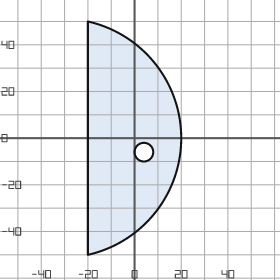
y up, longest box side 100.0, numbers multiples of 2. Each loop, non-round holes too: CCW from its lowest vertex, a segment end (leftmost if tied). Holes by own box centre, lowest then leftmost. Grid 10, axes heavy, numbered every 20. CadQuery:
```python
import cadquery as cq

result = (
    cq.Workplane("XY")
    .moveTo(-20.0, -50.0)
    .threePointArc((20.0, 0.0), (-20.0, 50.0))
    .close()
    .moveTo(4.0, -6.0)
    .circle(4.0)
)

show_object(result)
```